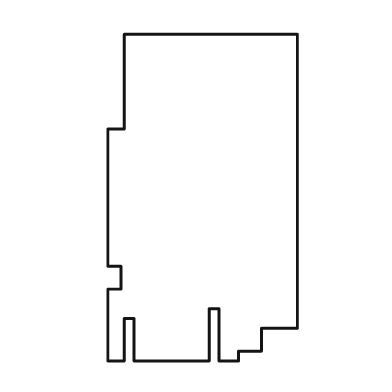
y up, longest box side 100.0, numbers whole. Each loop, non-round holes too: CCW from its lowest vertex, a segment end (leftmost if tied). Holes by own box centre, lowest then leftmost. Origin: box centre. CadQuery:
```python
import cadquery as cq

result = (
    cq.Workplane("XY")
    .moveTo(-29.0, -50.0)
    .lineTo(-24.0, -50.0)
    .lineTo(-24.0, -37.0)
    .lineTo(-21.0, -37.0)
    .lineTo(-21.0, -50.0)
    .lineTo(2.0, -50.0)
    .lineTo(2.0, -34.0)
    .lineTo(5.0, -34.0)
    .lineTo(5.0, -50.0)
    .lineTo(11.0, -50.0)
    .lineTo(11.0, -47.0)
    .lineTo(18.0, -47.0)
    .lineTo(18.0, -40.0)
    .lineTo(29.0, -40.0)
    .lineTo(29.0, 50.0)
    .lineTo(-24.0, 50.0)
    .lineTo(-24.0, 21.0)
    .lineTo(-29.0, 21.0)
    .lineTo(-29.0, -21.0)
    .lineTo(-25.0, -21.0)
    .lineTo(-25.0, -28.0)
    .lineTo(-29.0, -28.0)
    .close()
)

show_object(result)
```